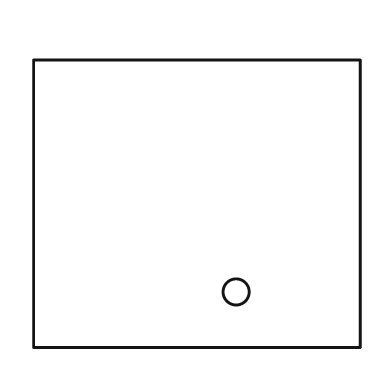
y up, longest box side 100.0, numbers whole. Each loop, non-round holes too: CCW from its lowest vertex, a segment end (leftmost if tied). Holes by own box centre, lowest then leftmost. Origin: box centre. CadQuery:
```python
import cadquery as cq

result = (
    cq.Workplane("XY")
    .moveTo(-50.0, -44.0)
    .lineTo(50.0, -44.0)
    .lineTo(50.0, 44.0)
    .lineTo(-50.0, 44.0)
    .close()
    .moveTo(12.0, -27.0)
    .circle(4.0)
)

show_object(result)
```